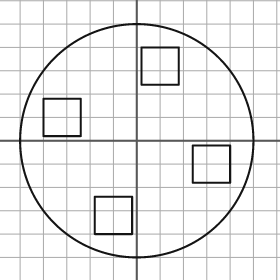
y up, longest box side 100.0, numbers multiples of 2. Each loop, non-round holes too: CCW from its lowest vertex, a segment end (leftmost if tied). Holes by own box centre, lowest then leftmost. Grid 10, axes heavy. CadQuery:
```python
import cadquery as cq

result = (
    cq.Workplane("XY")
    .moveTo(0.0, 0.0)
    .circle(50.0)
    .moveTo(-18.0, -40.0)
    .lineTo(-2.0, -40.0)
    .lineTo(-2.0, -24.0)
    .lineTo(-18.0, -24.0)
    .close()
    .moveTo(24.0, -18.0)
    .lineTo(40.0, -18.0)
    .lineTo(40.0, -2.0)
    .lineTo(24.0, -2.0)
    .close()
    .moveTo(-40.0, 2.0)
    .lineTo(-24.0, 2.0)
    .lineTo(-24.0, 18.0)
    .lineTo(-40.0, 18.0)
    .close()
    .moveTo(2.0, 24.0)
    .lineTo(18.0, 24.0)
    .lineTo(18.0, 40.0)
    .lineTo(2.0, 40.0)
    .close()
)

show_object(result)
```